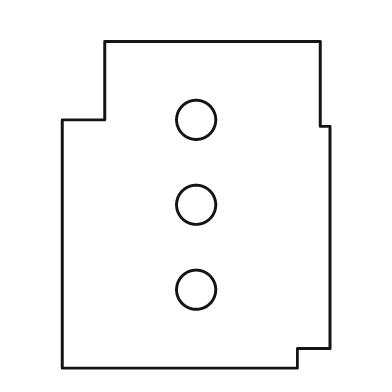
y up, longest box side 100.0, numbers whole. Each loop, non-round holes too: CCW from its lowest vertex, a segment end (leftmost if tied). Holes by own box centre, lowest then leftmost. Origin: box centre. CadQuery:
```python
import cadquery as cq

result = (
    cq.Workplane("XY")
    .moveTo(-41.0, -50.0)
    .lineTo(31.0, -50.0)
    .lineTo(31.0, -44.0)
    .lineTo(41.0, -44.0)
    .lineTo(41.0, 24.0)
    .lineTo(38.0, 24.0)
    .lineTo(38.0, 50.0)
    .lineTo(-28.0, 50.0)
    .lineTo(-28.0, 26.0)
    .lineTo(-41.0, 26.0)
    .close()
    .moveTo(0.0, -26.0)
    .circle(6.0)
    .moveTo(0.0, 0.0)
    .circle(6.0)
    .moveTo(0.0, 26.0)
    .circle(6.0)
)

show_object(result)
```